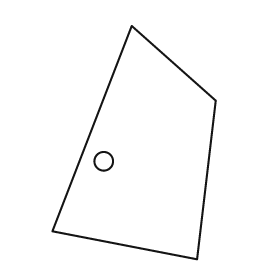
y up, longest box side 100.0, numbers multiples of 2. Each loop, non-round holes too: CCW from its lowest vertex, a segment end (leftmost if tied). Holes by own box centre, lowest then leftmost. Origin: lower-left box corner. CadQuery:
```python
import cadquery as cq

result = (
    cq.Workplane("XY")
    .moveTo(62.0, 0.0)
    .lineTo(70.0, 68.0)
    .lineTo(34.0, 100.0)
    .lineTo(0.0, 12.0)
    .close()
    .moveTo(22.0, 42.0)
    .circle(4.0)
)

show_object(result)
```